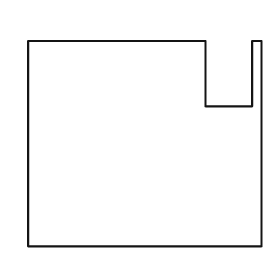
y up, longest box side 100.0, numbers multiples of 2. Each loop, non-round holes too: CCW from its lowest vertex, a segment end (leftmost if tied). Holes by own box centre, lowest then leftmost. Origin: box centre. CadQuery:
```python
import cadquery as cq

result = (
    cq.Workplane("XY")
    .moveTo(-50.0, -44.0)
    .lineTo(50.0, -44.0)
    .lineTo(50.0, 44.0)
    .lineTo(46.0, 44.0)
    .lineTo(46.0, 16.0)
    .lineTo(26.0, 16.0)
    .lineTo(26.0, 44.0)
    .lineTo(-50.0, 44.0)
    .close()
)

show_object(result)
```